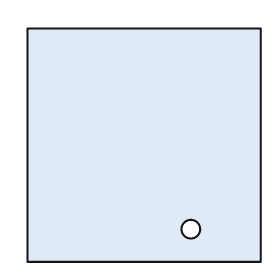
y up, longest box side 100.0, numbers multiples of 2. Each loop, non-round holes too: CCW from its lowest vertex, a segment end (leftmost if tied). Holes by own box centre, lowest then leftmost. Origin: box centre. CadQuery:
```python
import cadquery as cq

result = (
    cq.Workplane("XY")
    .moveTo(-50.0, -50.0)
    .lineTo(50.0, -50.0)
    .lineTo(50.0, 50.0)
    .lineTo(-50.0, 50.0)
    .close()
    .moveTo(20.0, -36.0)
    .circle(4.0)
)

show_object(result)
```